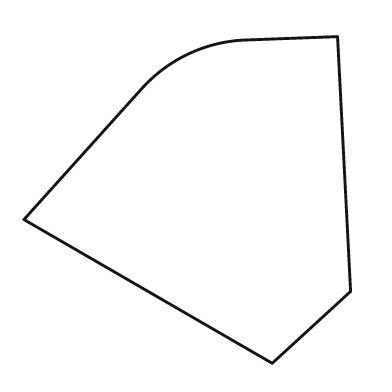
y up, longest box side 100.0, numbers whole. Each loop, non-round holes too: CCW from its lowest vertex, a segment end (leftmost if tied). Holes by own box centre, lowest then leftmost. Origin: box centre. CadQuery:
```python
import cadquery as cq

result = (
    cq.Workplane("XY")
    .moveTo(26.0, -50.0)
    .lineTo(50.0, -28.0)
    .lineTo(46.0, 50.0)
    .lineTo(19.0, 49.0)
    .threePointArc((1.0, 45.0), (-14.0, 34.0))
    .lineTo(-50.0, -6.0)
    .close()
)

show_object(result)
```